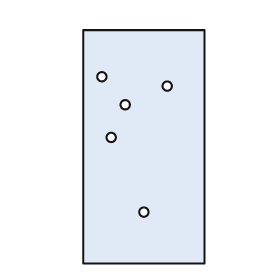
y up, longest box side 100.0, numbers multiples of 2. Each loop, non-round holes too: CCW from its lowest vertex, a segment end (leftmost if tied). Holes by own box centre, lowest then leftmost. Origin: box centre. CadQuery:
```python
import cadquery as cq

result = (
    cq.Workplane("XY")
    .moveTo(-26.0, -50.0)
    .lineTo(26.0, -50.0)
    .lineTo(26.0, 50.0)
    .lineTo(-26.0, 50.0)
    .close()
    .moveTo(0.0, -28.0)
    .circle(2.0)
    .moveTo(-14.0, 4.0)
    .circle(2.0)
    .moveTo(-8.0, 18.0)
    .circle(2.0)
    .moveTo(10.0, 26.0)
    .circle(2.0)
    .moveTo(-18.0, 30.0)
    .circle(2.0)
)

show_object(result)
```